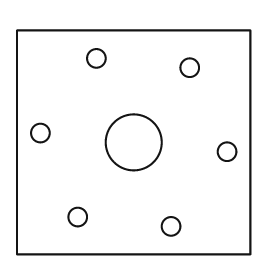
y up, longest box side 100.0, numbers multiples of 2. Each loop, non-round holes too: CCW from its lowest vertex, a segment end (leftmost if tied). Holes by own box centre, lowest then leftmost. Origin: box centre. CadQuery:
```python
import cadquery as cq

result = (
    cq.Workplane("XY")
    .moveTo(-50.0, -48.0)
    .lineTo(50.0, -48.0)
    .lineTo(50.0, 48.0)
    .lineTo(-50.0, 48.0)
    .close()
    .moveTo(16.0, -36.0)
    .circle(4.0)
    .moveTo(-24.0, -32.0)
    .circle(4.0)
    .moveTo(40.0, -4.0)
    .circle(4.0)
    .moveTo(0.0, 0.0)
    .circle(12.0)
    .moveTo(-40.0, 4.0)
    .circle(4.0)
    .moveTo(24.0, 32.0)
    .circle(4.0)
    .moveTo(-16.0, 36.0)
    .circle(4.0)
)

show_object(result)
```